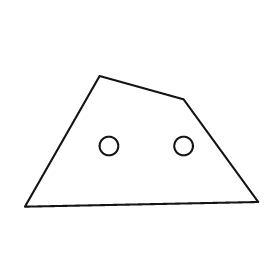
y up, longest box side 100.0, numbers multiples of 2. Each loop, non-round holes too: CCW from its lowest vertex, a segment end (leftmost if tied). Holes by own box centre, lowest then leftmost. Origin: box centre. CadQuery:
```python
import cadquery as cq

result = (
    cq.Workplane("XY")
    .moveTo(-50.0, -28.0)
    .lineTo(50.0, -26.0)
    .lineTo(18.0, 18.0)
    .lineTo(-18.0, 28.0)
    .close()
    .moveTo(-14.0, -2.0)
    .circle(4.0)
    .moveTo(18.0, -2.0)
    .circle(4.0)
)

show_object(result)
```